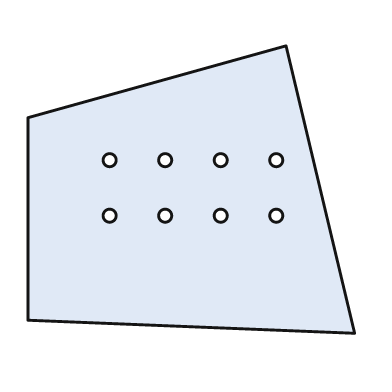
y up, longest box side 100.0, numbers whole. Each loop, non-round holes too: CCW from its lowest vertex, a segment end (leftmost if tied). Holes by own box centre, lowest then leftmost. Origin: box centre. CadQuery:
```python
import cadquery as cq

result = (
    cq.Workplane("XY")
    .moveTo(50.0, -44.0)
    .lineTo(29.0, 44.0)
    .lineTo(-50.0, 22.0)
    .lineTo(-50.0, -40.0)
    .close()
    .moveTo(-25.0, -8.0)
    .circle(2.0)
    .moveTo(-8.0, -8.0)
    .circle(2.0)
    .moveTo(9.0, -8.0)
    .circle(2.0)
    .moveTo(26.0, -8.0)
    .circle(2.0)
    .moveTo(-25.0, 9.0)
    .circle(2.0)
    .moveTo(-8.0, 9.0)
    .circle(2.0)
    .moveTo(9.0, 9.0)
    .circle(2.0)
    .moveTo(26.0, 9.0)
    .circle(2.0)
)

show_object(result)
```